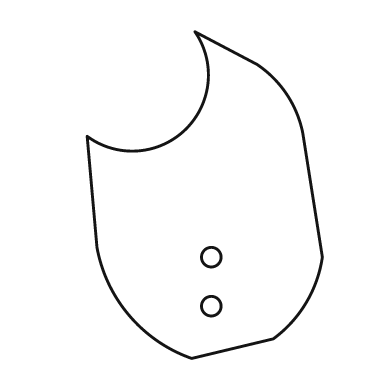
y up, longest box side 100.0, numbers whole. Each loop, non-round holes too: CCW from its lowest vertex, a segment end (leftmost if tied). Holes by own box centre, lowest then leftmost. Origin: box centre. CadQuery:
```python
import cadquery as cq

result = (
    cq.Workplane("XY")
    .moveTo(-4.0, -50.0)
    .lineTo(21.0, -44.0)
    .threePointArc((31.0, -33.0), (36.0, -19.0))
    .lineTo(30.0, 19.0)
    .threePointArc((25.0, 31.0), (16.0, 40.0))
    .lineTo(-3.0, 50.0)
    .threePointArc((-6.0, 20.0), (-36.0, 18.0))
    .lineTo(-33.0, -16.0)
    .threePointArc((-23.0, -37.0), (-4.0, -50.0))
    .close()
    .moveTo(2.0, -34.0)
    .circle(3.0)
    .moveTo(2.0, -19.0)
    .circle(3.0)
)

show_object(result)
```